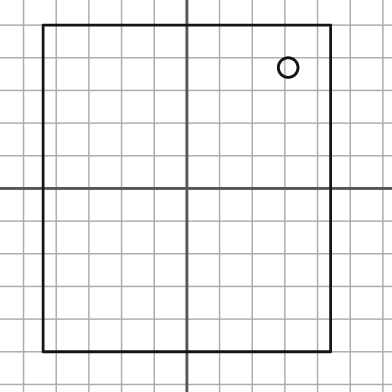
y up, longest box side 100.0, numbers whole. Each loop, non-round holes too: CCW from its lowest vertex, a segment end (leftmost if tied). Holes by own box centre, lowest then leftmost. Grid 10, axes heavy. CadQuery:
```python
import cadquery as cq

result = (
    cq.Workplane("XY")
    .moveTo(-44.0, -50.0)
    .lineTo(44.0, -50.0)
    .lineTo(44.0, 50.0)
    .lineTo(-44.0, 50.0)
    .close()
    .moveTo(31.0, 37.0)
    .circle(3.0)
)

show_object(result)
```